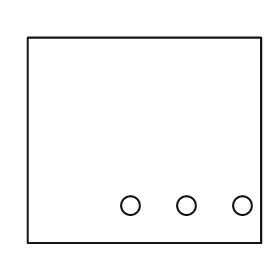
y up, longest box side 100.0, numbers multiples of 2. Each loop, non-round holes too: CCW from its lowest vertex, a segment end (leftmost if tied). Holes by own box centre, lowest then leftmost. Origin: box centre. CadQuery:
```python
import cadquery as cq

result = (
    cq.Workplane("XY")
    .moveTo(-50.0, -44.0)
    .lineTo(50.0, -44.0)
    .lineTo(50.0, 44.0)
    .lineTo(-50.0, 44.0)
    .close()
    .moveTo(-6.0, -28.0)
    .circle(4.0)
    .moveTo(18.0, -28.0)
    .circle(4.0)
    .moveTo(42.0, -28.0)
    .circle(4.0)
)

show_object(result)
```